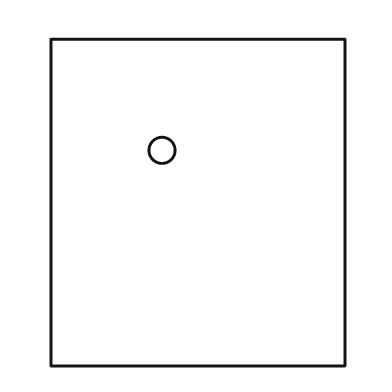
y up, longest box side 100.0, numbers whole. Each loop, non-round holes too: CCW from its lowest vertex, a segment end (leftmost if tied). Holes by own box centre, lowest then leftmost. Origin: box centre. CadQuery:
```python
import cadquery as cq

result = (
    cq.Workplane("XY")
    .moveTo(-45.0, -50.0)
    .lineTo(45.0, -50.0)
    .lineTo(45.0, 50.0)
    .lineTo(-45.0, 50.0)
    .close()
    .moveTo(-11.0, 16.0)
    .circle(4.0)
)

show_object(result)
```